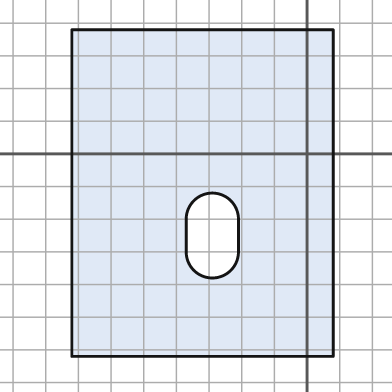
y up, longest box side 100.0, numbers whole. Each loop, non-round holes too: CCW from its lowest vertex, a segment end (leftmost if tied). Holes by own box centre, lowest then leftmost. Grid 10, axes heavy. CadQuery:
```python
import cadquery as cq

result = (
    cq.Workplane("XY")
    .moveTo(-72.0, -62.0)
    .lineTo(8.0, -62.0)
    .lineTo(8.0, 38.0)
    .lineTo(-72.0, 38.0)
    .close()
    .moveTo(-37.0, -30.0)
    .threePointArc((-29.0, -38.0), (-21.0, -30.0))
    .lineTo(-21.0, -20.0)
    .threePointArc((-29.0, -12.0), (-37.0, -20.0))
    .close()
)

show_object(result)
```